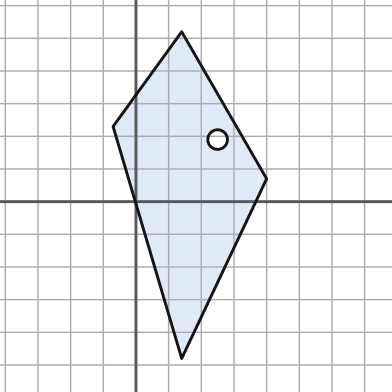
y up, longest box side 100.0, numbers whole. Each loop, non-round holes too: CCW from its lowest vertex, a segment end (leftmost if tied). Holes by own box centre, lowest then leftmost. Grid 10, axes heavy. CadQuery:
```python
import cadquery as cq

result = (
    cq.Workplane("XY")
    .moveTo(14.0, -48.0)
    .lineTo(40.0, 7.0)
    .lineTo(14.0, 52.0)
    .lineTo(-7.0, 23.0)
    .close()
    .moveTo(25.0, 19.0)
    .circle(3.0)
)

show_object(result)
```